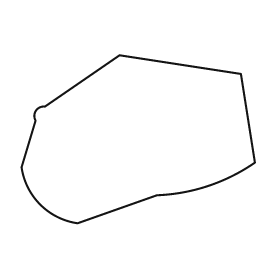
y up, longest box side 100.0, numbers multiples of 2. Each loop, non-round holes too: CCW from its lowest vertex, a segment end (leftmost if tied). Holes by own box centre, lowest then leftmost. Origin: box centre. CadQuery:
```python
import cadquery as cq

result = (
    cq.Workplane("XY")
    .moveTo(-26.0, -36.0)
    .lineTo(8.0, -24.0)
    .threePointArc((30.0, -20.0), (50.0, -10.0))
    .lineTo(44.0, 28.0)
    .lineTo(-8.0, 36.0)
    .lineTo(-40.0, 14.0)
    .threePointArc((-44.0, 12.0), (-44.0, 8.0))
    .lineTo(-50.0, -12.0)
    .threePointArc((-42.0, -28.0), (-26.0, -36.0))
    .close()
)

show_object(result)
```